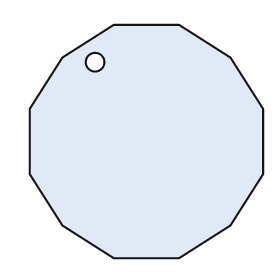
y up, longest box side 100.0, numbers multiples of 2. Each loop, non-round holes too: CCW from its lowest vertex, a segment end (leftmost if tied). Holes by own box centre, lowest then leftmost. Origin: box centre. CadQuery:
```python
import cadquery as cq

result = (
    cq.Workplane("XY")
    .moveTo(-14.0, -50.0)
    .lineTo(14.0, -50.0)
    .lineTo(36.0, -36.0)
    .lineTo(50.0, -14.0)
    .lineTo(50.0, 14.0)
    .lineTo(36.0, 36.0)
    .lineTo(14.0, 50.0)
    .lineTo(-14.0, 50.0)
    .lineTo(-36.0, 36.0)
    .lineTo(-50.0, 14.0)
    .lineTo(-50.0, -14.0)
    .lineTo(-36.0, -36.0)
    .close()
    .moveTo(-22.0, 34.0)
    .circle(4.0)
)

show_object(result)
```